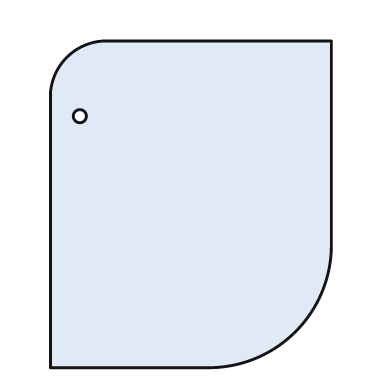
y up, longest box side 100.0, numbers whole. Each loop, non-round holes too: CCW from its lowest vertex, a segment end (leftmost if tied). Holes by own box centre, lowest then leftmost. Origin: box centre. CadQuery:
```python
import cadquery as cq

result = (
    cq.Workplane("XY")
    .moveTo(-43.0, -50.0)
    .lineTo(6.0, -50.0)
    .threePointArc((32.0, -39.0), (43.0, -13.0))
    .lineTo(43.0, 50.0)
    .lineTo(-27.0, 50.0)
    .threePointArc((-38.0, 45.0), (-43.0, 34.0))
    .close()
    .moveTo(-34.0, 27.0)
    .circle(2.0)
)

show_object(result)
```